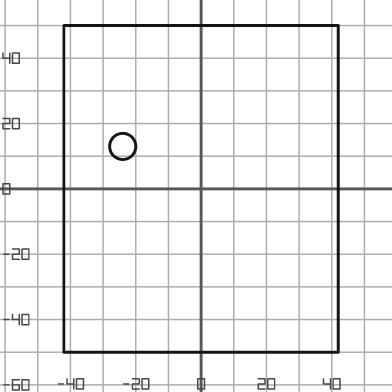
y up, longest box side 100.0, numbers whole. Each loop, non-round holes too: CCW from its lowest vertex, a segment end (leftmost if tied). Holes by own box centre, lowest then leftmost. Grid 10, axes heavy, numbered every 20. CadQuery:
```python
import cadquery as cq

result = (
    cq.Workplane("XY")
    .moveTo(-42.0, -50.0)
    .lineTo(42.0, -50.0)
    .lineTo(42.0, 50.0)
    .lineTo(-42.0, 50.0)
    .close()
    .moveTo(-24.0, 13.0)
    .circle(4.0)
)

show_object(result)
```